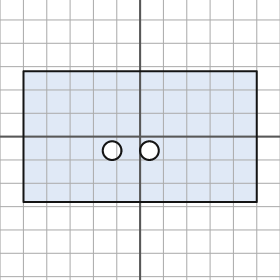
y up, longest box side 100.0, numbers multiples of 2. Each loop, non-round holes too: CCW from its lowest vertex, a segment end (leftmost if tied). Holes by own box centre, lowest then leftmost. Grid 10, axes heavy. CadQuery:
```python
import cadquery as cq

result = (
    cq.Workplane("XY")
    .moveTo(-50.0, -28.0)
    .lineTo(50.0, -28.0)
    .lineTo(50.0, 28.0)
    .lineTo(-50.0, 28.0)
    .close()
    .moveTo(-12.0, -6.0)
    .circle(4.0)
    .moveTo(4.0, -6.0)
    .circle(4.0)
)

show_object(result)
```